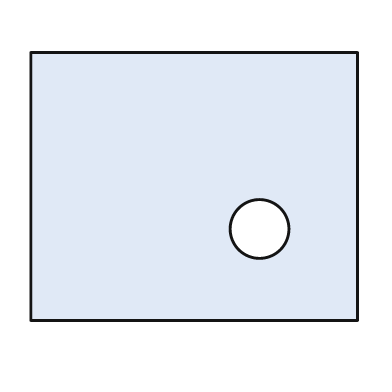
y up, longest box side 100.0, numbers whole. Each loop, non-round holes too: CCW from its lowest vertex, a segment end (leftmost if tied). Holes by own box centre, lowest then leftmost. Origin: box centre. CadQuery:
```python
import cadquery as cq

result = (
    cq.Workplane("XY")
    .moveTo(-50.0, -41.0)
    .lineTo(50.0, -41.0)
    .lineTo(50.0, 41.0)
    .lineTo(-50.0, 41.0)
    .close()
    .moveTo(20.0, -13.0)
    .circle(9.0)
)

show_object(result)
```